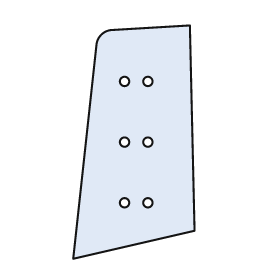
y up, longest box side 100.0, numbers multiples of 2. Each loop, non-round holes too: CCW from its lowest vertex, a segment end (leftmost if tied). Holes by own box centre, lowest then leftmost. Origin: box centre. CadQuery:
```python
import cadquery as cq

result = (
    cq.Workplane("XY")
    .moveTo(-26.0, -50.0)
    .lineTo(26.0, -38.0)
    .lineTo(24.0, 50.0)
    .lineTo(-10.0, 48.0)
    .threePointArc((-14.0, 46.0), (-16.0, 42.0))
    .close()
    .moveTo(-4.0, -26.0)
    .circle(2.0)
    .moveTo(6.0, -26.0)
    .circle(2.0)
    .moveTo(-4.0, 0.0)
    .circle(2.0)
    .moveTo(6.0, 0.0)
    .circle(2.0)
    .moveTo(-4.0, 26.0)
    .circle(2.0)
    .moveTo(6.0, 26.0)
    .circle(2.0)
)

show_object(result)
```